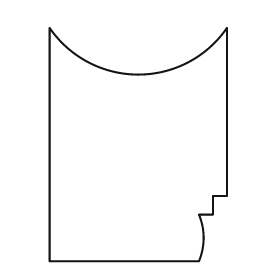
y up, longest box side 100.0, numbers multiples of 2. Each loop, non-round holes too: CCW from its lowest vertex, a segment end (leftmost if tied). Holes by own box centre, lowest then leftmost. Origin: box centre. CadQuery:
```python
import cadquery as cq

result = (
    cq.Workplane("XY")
    .moveTo(-38.0, -50.0)
    .lineTo(26.0, -50.0)
    .threePointArc((28.0, -40.0), (26.0, -30.0))
    .lineTo(32.0, -30.0)
    .lineTo(32.0, -22.0)
    .lineTo(38.0, -22.0)
    .lineTo(38.0, 50.0)
    .threePointArc((0.0, 30.0), (-38.0, 50.0))
    .close()
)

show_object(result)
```